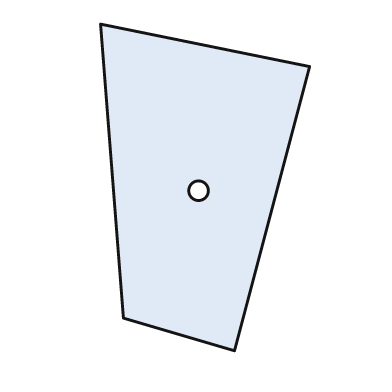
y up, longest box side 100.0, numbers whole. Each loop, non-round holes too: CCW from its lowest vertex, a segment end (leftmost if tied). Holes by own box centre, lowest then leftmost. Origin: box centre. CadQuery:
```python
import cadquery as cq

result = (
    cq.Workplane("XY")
    .moveTo(9.0, -50.0)
    .lineTo(32.0, 37.0)
    .lineTo(-32.0, 50.0)
    .lineTo(-25.0, -40.0)
    .close()
    .moveTo(-2.0, -1.0)
    .circle(3.0)
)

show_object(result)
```